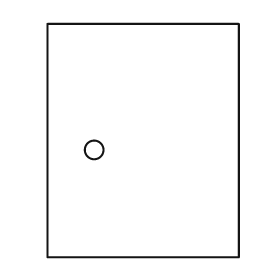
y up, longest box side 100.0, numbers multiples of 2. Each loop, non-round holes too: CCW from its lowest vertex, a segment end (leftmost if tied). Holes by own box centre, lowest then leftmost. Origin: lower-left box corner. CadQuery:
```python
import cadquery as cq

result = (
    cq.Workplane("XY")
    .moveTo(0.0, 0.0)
    .lineTo(82.0, 0.0)
    .lineTo(82.0, 100.0)
    .lineTo(0.0, 100.0)
    .close()
    .moveTo(20.0, 46.0)
    .circle(4.0)
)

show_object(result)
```